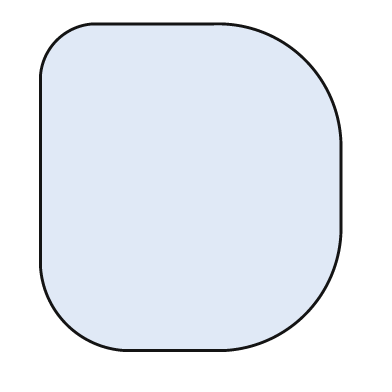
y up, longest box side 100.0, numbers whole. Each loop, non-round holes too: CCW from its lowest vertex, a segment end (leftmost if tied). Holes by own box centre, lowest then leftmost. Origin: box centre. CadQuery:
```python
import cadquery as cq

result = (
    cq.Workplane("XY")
    .moveTo(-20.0, -50.0)
    .lineTo(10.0, -50.0)
    .threePointArc((35.0, -39.0), (46.0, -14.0))
    .lineTo(46.0, 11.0)
    .threePointArc((35.0, 39.0), (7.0, 50.0))
    .lineTo(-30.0, 50.0)
    .threePointArc((-41.0, 45.0), (-46.0, 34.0))
    .lineTo(-46.0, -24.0)
    .threePointArc((-38.0, -42.0), (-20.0, -50.0))
    .close()
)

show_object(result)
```